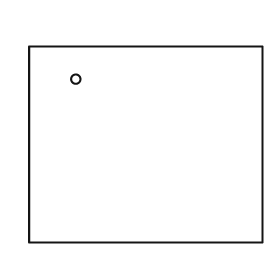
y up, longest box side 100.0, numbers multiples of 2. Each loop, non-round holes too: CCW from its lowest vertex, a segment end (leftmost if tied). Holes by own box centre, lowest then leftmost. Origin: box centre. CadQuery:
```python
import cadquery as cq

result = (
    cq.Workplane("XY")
    .moveTo(-50.0, -42.0)
    .lineTo(50.0, -42.0)
    .lineTo(50.0, 42.0)
    .lineTo(-50.0, 42.0)
    .close()
    .moveTo(-30.0, 28.0)
    .circle(2.0)
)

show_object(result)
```